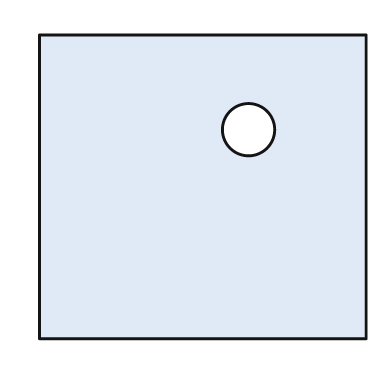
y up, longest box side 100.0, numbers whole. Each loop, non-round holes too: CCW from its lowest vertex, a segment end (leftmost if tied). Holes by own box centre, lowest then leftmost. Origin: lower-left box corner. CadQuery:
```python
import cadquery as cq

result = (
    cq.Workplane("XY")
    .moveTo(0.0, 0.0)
    .lineTo(100.0, 0.0)
    .lineTo(100.0, 93.0)
    .lineTo(0.0, 93.0)
    .close()
    .moveTo(64.0, 64.0)
    .circle(8.0)
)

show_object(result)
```